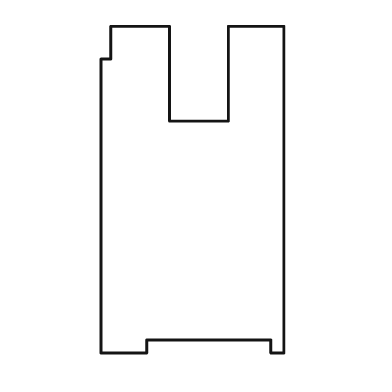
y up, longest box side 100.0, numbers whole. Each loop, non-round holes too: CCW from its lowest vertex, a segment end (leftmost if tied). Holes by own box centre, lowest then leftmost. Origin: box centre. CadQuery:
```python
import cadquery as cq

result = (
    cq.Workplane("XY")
    .moveTo(-28.0, -50.0)
    .lineTo(-14.0, -50.0)
    .lineTo(-14.0, -46.0)
    .lineTo(24.0, -46.0)
    .lineTo(24.0, -50.0)
    .lineTo(28.0, -50.0)
    .lineTo(28.0, 50.0)
    .lineTo(11.0, 50.0)
    .lineTo(11.0, 21.0)
    .lineTo(-7.0, 21.0)
    .lineTo(-7.0, 50.0)
    .lineTo(-25.0, 50.0)
    .lineTo(-25.0, 40.0)
    .lineTo(-28.0, 40.0)
    .close()
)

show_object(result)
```